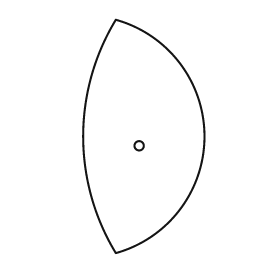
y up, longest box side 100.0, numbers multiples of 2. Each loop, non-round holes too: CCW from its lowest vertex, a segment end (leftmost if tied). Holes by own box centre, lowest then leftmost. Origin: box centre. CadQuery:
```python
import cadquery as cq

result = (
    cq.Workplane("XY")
    .moveTo(-12.0, -50.0)
    .threePointArc((26.0, 0.0), (-12.0, 50.0))
    .threePointArc((-26.0, 0.0), (-12.0, -50.0))
    .close()
    .moveTo(-2.0, -4.0)
    .circle(2.0)
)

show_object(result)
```